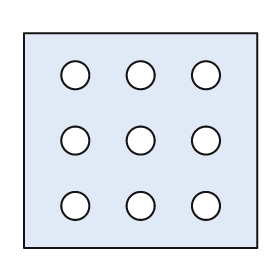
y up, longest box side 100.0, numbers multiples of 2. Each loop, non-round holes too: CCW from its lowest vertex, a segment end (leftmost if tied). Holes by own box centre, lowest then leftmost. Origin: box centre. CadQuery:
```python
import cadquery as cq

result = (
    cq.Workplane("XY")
    .moveTo(-50.0, -46.0)
    .lineTo(50.0, -46.0)
    .lineTo(50.0, 46.0)
    .lineTo(-50.0, 46.0)
    .close()
    .moveTo(-28.0, -28.0)
    .circle(6.0)
    .moveTo(0.0, -28.0)
    .circle(6.0)
    .moveTo(28.0, -28.0)
    .circle(6.0)
    .moveTo(-28.0, 0.0)
    .circle(6.0)
    .moveTo(0.0, 0.0)
    .circle(6.0)
    .moveTo(28.0, 0.0)
    .circle(6.0)
    .moveTo(-28.0, 28.0)
    .circle(6.0)
    .moveTo(0.0, 28.0)
    .circle(6.0)
    .moveTo(28.0, 28.0)
    .circle(6.0)
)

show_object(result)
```